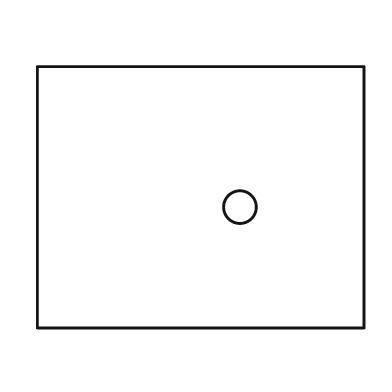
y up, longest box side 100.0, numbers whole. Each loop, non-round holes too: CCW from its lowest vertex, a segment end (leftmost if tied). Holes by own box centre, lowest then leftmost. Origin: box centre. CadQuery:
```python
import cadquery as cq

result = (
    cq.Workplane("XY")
    .moveTo(-50.0, -40.0)
    .lineTo(50.0, -40.0)
    .lineTo(50.0, 40.0)
    .lineTo(-50.0, 40.0)
    .close()
    .moveTo(12.0, -3.0)
    .circle(5.0)
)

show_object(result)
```